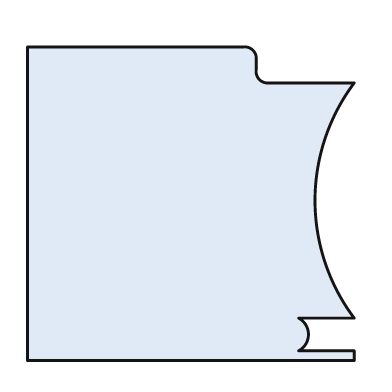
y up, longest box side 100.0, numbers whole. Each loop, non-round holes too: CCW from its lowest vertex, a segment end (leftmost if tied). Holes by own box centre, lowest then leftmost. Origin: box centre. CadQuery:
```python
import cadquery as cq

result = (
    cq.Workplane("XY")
    .moveTo(-50.0, -48.0)
    .lineTo(50.0, -48.0)
    .lineTo(50.0, -45.0)
    .lineTo(33.0, -45.0)
    .threePointArc((36.0, -40.0), (33.0, -35.0))
    .lineTo(50.0, -35.0)
    .threePointArc((38.0, 1.0), (50.0, 37.0))
    .lineTo(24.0, 37.0)
    .threePointArc((21.0, 38.0), (20.0, 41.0))
    .lineTo(20.0, 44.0)
    .threePointArc((19.0, 47.0), (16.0, 48.0))
    .lineTo(-50.0, 48.0)
    .close()
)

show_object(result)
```